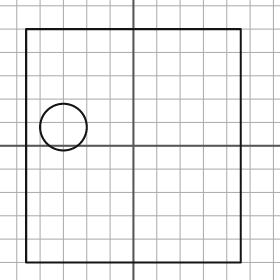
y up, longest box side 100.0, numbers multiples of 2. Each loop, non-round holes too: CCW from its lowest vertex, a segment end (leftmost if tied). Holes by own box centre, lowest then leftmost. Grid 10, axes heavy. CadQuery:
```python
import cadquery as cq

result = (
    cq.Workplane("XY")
    .moveTo(-46.0, -50.0)
    .lineTo(46.0, -50.0)
    .lineTo(46.0, 50.0)
    .lineTo(-46.0, 50.0)
    .close()
    .moveTo(-30.0, 8.0)
    .circle(10.0)
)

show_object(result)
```